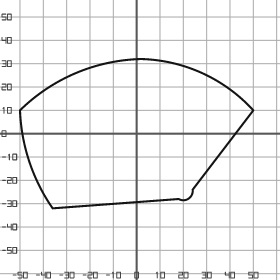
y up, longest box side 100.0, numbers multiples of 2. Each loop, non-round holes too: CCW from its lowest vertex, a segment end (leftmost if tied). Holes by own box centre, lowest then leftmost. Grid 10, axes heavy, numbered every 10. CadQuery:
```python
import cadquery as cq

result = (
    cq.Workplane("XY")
    .moveTo(-36.0, -32.0)
    .lineTo(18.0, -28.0)
    .threePointArc((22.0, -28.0), (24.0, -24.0))
    .lineTo(50.0, 10.0)
    .threePointArc((28.0, 26.0), (2.0, 32.0))
    .threePointArc((-26.0, 26.0), (-50.0, 10.0))
    .threePointArc((-46.0, -12.0), (-36.0, -32.0))
    .close()
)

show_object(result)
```